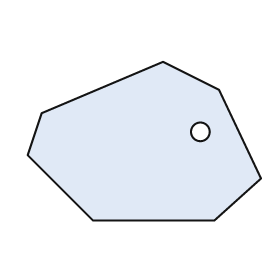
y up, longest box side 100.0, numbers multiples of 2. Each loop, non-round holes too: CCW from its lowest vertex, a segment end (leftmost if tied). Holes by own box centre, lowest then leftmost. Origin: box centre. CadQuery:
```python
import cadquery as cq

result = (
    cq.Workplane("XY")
    .moveTo(-22.0, -34.0)
    .lineTo(30.0, -34.0)
    .lineTo(50.0, -16.0)
    .lineTo(32.0, 22.0)
    .lineTo(8.0, 34.0)
    .lineTo(-44.0, 12.0)
    .lineTo(-50.0, -6.0)
    .close()
    .moveTo(24.0, 4.0)
    .circle(4.0)
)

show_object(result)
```